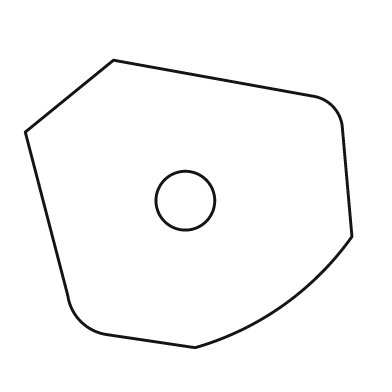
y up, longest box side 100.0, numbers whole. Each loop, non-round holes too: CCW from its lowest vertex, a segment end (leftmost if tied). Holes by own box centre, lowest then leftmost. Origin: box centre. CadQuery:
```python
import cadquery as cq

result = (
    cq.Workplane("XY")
    .moveTo(2.0, -44.0)
    .threePointArc((29.0, -31.0), (50.0, -10.0))
    .lineTo(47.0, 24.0)
    .threePointArc((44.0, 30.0), (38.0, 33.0))
    .lineTo(-23.0, 44.0)
    .lineTo(-50.0, 22.0)
    .lineTo(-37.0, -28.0)
    .threePointArc((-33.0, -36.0), (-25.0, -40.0))
    .close()
    .moveTo(-1.0, 1.0)
    .circle(9.0)
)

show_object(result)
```